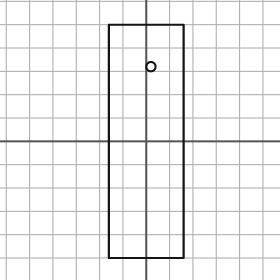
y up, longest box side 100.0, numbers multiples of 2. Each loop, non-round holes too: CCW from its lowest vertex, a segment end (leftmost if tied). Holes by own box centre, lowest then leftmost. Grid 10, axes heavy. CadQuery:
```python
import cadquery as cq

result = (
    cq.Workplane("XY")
    .moveTo(-16.0, -50.0)
    .lineTo(16.0, -50.0)
    .lineTo(16.0, 50.0)
    .lineTo(-16.0, 50.0)
    .close()
    .moveTo(2.0, 32.0)
    .circle(2.0)
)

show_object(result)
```